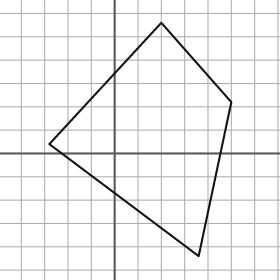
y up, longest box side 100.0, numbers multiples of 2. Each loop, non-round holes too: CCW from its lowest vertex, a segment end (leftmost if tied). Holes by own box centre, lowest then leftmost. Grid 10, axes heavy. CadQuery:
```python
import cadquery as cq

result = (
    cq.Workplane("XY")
    .moveTo(36.0, -44.0)
    .lineTo(50.0, 22.0)
    .lineTo(20.0, 56.0)
    .lineTo(-28.0, 4.0)
    .close()
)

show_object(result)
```